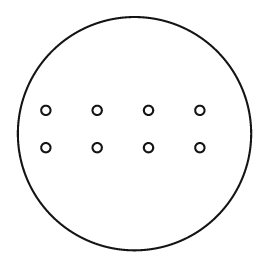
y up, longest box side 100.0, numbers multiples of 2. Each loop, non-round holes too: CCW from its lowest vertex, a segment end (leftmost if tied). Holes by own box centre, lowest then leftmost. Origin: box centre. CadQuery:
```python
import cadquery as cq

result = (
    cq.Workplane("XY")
    .moveTo(0.0, 0.0)
    .circle(50.0)
    .moveTo(-38.0, -6.0)
    .circle(2.0)
    .moveTo(-16.0, -6.0)
    .circle(2.0)
    .moveTo(6.0, -6.0)
    .circle(2.0)
    .moveTo(28.0, -6.0)
    .circle(2.0)
    .moveTo(-38.0, 10.0)
    .circle(2.0)
    .moveTo(-16.0, 10.0)
    .circle(2.0)
    .moveTo(6.0, 10.0)
    .circle(2.0)
    .moveTo(28.0, 10.0)
    .circle(2.0)
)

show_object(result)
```